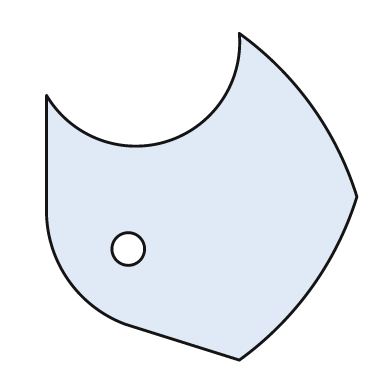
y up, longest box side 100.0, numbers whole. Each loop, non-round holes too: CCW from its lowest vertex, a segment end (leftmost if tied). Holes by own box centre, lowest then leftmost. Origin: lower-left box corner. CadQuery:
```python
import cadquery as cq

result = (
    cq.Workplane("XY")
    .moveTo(59.0, 0.0)
    .threePointArc((81.0, 22.0), (95.0, 50.0))
    .threePointArc((81.0, 78.0), (59.0, 100.0))
    .threePointArc((37.0, 67.0), (0.0, 81.0))
    .lineTo(0.0, 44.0)
    .threePointArc((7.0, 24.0), (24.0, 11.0))
    .close()
    .moveTo(25.0, 34.0)
    .circle(5.0)
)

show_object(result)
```